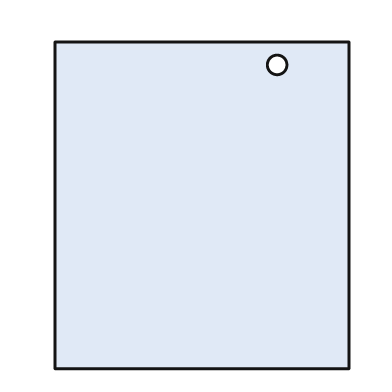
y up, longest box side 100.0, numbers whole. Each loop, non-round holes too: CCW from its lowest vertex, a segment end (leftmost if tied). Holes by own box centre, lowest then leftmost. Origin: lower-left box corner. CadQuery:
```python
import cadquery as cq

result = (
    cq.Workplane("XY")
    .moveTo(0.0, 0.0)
    .lineTo(90.0, 0.0)
    .lineTo(90.0, 100.0)
    .lineTo(0.0, 100.0)
    .close()
    .moveTo(68.0, 93.0)
    .circle(3.0)
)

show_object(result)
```